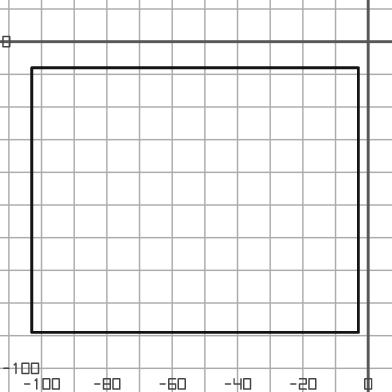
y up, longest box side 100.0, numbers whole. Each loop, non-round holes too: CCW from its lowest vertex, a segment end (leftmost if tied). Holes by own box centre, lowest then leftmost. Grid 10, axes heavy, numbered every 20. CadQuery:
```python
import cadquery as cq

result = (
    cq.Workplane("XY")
    .moveTo(-103.0, -89.0)
    .lineTo(-3.0, -89.0)
    .lineTo(-3.0, -8.0)
    .lineTo(-103.0, -8.0)
    .close()
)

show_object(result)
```